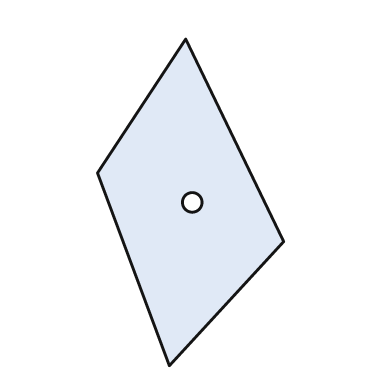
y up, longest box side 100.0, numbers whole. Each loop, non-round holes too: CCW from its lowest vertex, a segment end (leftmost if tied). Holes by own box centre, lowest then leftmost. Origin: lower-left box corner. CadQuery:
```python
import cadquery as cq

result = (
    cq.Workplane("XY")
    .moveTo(22.0, 0.0)
    .lineTo(57.0, 38.0)
    .lineTo(27.0, 100.0)
    .lineTo(0.0, 59.0)
    .close()
    .moveTo(29.0, 50.0)
    .circle(3.0)
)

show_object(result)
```